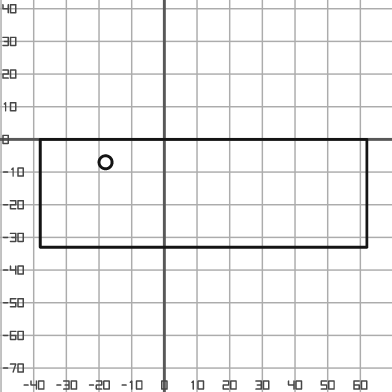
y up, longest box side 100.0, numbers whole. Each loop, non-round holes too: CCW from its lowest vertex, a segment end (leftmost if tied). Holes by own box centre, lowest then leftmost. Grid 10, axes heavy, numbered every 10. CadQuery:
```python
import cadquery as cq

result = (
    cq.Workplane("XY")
    .moveTo(-38.0, -33.0)
    .lineTo(62.0, -33.0)
    .lineTo(62.0, 0.0)
    .lineTo(-38.0, 0.0)
    .close()
    .moveTo(-18.0, -7.0)
    .circle(2.0)
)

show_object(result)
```